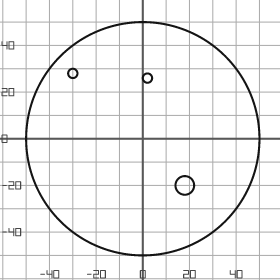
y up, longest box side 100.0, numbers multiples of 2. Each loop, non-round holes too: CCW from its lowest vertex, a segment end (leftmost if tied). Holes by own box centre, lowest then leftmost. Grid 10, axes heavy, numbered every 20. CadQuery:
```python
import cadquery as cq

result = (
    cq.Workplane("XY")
    .moveTo(0.0, 0.0)
    .circle(50.0)
    .moveTo(18.0, -20.0)
    .circle(4.0)
    .moveTo(2.0, 26.0)
    .circle(2.0)
    .moveTo(-30.0, 28.0)
    .circle(2.0)
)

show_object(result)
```